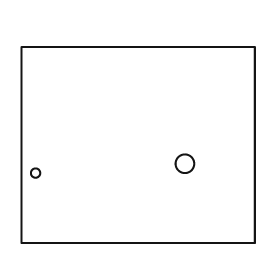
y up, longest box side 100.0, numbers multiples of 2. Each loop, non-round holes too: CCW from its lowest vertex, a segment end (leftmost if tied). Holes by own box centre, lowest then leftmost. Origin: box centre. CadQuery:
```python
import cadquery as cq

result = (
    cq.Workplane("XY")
    .moveTo(-50.0, -42.0)
    .lineTo(50.0, -42.0)
    .lineTo(50.0, 42.0)
    .lineTo(-50.0, 42.0)
    .close()
    .moveTo(-44.0, -12.0)
    .circle(2.0)
    .moveTo(20.0, -8.0)
    .circle(4.0)
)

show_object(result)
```